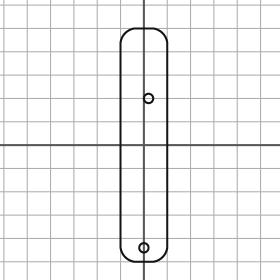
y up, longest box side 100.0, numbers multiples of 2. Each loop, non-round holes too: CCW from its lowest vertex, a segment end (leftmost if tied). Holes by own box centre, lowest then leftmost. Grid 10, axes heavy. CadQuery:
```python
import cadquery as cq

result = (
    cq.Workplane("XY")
    .moveTo(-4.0, -50.0)
    .lineTo(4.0, -50.0)
    .threePointArc((8.0, -48.0), (10.0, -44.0))
    .lineTo(10.0, 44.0)
    .threePointArc((8.0, 48.0), (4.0, 50.0))
    .lineTo(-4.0, 50.0)
    .threePointArc((-8.0, 48.0), (-10.0, 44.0))
    .lineTo(-10.0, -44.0)
    .threePointArc((-8.0, -48.0), (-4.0, -50.0))
    .close()
    .moveTo(0.0, -44.0)
    .circle(2.0)
    .moveTo(2.0, 20.0)
    .circle(2.0)
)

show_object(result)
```